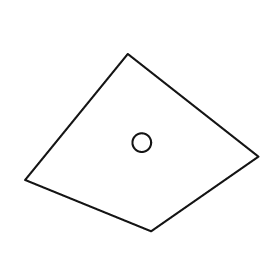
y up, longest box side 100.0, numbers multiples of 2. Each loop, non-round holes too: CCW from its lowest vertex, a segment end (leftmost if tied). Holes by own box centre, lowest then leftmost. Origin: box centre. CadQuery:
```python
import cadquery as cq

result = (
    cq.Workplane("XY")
    .moveTo(4.0, -38.0)
    .lineTo(50.0, -6.0)
    .lineTo(-6.0, 38.0)
    .lineTo(-50.0, -16.0)
    .close()
    .moveTo(0.0, 0.0)
    .circle(4.0)
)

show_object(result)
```